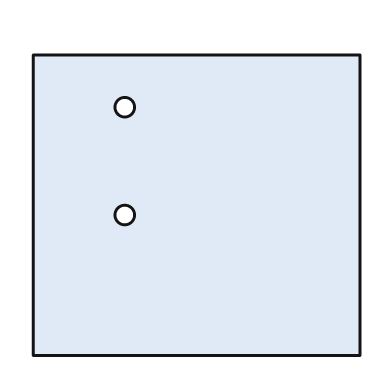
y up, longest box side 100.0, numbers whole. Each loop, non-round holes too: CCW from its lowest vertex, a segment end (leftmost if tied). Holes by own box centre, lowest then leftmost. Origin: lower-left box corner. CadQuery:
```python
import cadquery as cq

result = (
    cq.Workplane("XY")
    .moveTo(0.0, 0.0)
    .lineTo(100.0, 0.0)
    .lineTo(100.0, 92.0)
    .lineTo(0.0, 92.0)
    .close()
    .moveTo(28.0, 43.0)
    .circle(3.0)
    .moveTo(28.0, 76.0)
    .circle(3.0)
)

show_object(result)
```